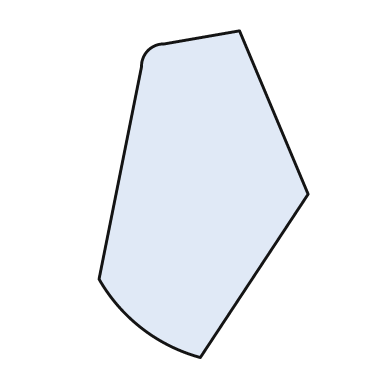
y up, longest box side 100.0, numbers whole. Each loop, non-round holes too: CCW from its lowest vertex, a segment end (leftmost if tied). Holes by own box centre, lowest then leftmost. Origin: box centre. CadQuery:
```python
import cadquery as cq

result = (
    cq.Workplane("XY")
    .moveTo(-1.0, -50.0)
    .lineTo(32.0, 0.0)
    .lineTo(11.0, 50.0)
    .lineTo(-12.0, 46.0)
    .threePointArc((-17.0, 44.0), (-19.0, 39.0))
    .lineTo(-32.0, -26.0)
    .threePointArc((-19.0, -41.0), (-1.0, -50.0))
    .close()
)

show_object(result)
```